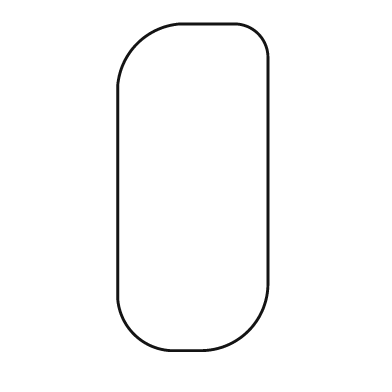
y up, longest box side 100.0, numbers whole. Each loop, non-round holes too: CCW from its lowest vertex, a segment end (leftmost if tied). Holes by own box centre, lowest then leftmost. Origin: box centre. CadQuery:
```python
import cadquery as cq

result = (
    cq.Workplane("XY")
    .moveTo(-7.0, -50.0)
    .lineTo(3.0, -50.0)
    .threePointArc((17.0, -44.0), (23.0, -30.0))
    .lineTo(23.0, 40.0)
    .threePointArc((20.0, 47.0), (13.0, 50.0))
    .lineTo(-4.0, 50.0)
    .threePointArc((-17.0, 44.0), (-23.0, 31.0))
    .lineTo(-23.0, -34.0)
    .threePointArc((-18.0, -45.0), (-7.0, -50.0))
    .close()
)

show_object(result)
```